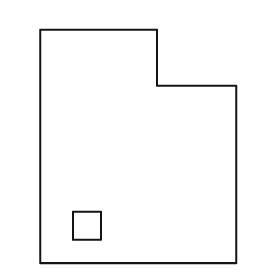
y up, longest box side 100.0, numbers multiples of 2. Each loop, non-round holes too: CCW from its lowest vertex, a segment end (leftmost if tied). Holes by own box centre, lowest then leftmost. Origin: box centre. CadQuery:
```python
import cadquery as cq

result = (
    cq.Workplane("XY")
    .moveTo(-42.0, -50.0)
    .lineTo(42.0, -50.0)
    .lineTo(42.0, 26.0)
    .lineTo(8.0, 26.0)
    .lineTo(8.0, 50.0)
    .lineTo(-42.0, 50.0)
    .close()
    .moveTo(-28.0, -40.0)
    .lineTo(-16.0, -40.0)
    .lineTo(-16.0, -28.0)
    .lineTo(-28.0, -28.0)
    .close()
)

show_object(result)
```